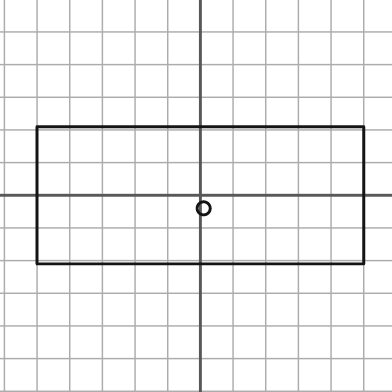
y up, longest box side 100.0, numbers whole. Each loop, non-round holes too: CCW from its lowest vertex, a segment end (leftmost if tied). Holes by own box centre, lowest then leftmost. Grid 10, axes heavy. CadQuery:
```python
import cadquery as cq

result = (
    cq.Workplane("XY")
    .moveTo(-50.0, -21.0)
    .lineTo(50.0, -21.0)
    .lineTo(50.0, 21.0)
    .lineTo(-50.0, 21.0)
    .close()
    .moveTo(1.0, -4.0)
    .circle(2.0)
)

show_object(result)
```